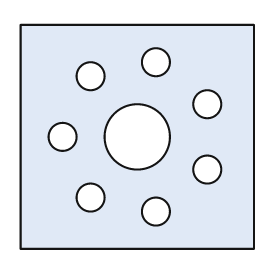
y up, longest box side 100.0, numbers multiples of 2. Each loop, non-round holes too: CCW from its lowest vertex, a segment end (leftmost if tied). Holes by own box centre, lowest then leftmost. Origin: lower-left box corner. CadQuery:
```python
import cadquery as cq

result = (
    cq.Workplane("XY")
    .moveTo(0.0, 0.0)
    .lineTo(100.0, 0.0)
    .lineTo(100.0, 96.0)
    .lineTo(0.0, 96.0)
    .close()
    .moveTo(58.0, 16.0)
    .circle(6.0)
    .moveTo(30.0, 22.0)
    .circle(6.0)
    .moveTo(80.0, 34.0)
    .circle(6.0)
    .moveTo(18.0, 48.0)
    .circle(6.0)
    .moveTo(50.0, 48.0)
    .circle(14.0)
    .moveTo(80.0, 62.0)
    .circle(6.0)
    .moveTo(30.0, 74.0)
    .circle(6.0)
    .moveTo(58.0, 80.0)
    .circle(6.0)
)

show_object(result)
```